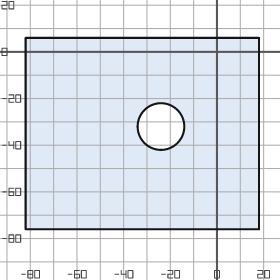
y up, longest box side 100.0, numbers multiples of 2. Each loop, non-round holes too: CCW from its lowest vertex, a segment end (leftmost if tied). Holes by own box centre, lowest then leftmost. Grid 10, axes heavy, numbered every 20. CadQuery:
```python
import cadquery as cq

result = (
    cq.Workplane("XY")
    .moveTo(-82.0, -76.0)
    .lineTo(18.0, -76.0)
    .lineTo(18.0, 6.0)
    .lineTo(-82.0, 6.0)
    .close()
    .moveTo(-24.0, -32.0)
    .circle(10.0)
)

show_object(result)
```